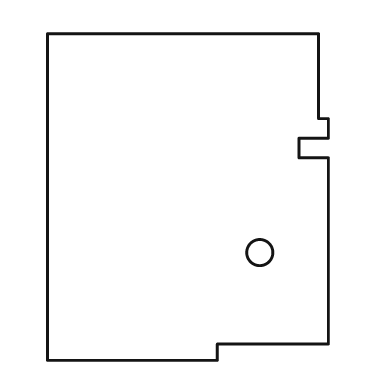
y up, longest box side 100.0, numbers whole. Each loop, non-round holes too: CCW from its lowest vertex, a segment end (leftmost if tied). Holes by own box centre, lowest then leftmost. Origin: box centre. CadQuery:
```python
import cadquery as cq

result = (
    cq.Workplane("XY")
    .moveTo(-43.0, -50.0)
    .lineTo(9.0, -50.0)
    .lineTo(9.0, -45.0)
    .lineTo(43.0, -45.0)
    .lineTo(43.0, 12.0)
    .lineTo(34.0, 12.0)
    .lineTo(34.0, 18.0)
    .lineTo(43.0, 18.0)
    .lineTo(43.0, 24.0)
    .lineTo(40.0, 24.0)
    .lineTo(40.0, 50.0)
    .lineTo(-43.0, 50.0)
    .close()
    .moveTo(22.0, -17.0)
    .circle(4.0)
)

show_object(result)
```